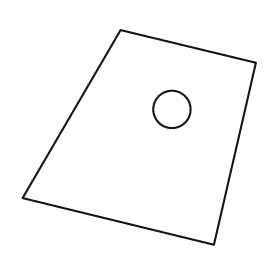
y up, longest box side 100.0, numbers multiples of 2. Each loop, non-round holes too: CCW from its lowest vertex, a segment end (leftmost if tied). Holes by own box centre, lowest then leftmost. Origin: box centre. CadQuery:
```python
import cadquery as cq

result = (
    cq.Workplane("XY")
    .moveTo(32.0, -46.0)
    .lineTo(50.0, 32.0)
    .lineTo(-8.0, 46.0)
    .lineTo(-50.0, -26.0)
    .close()
    .moveTo(14.0, 12.0)
    .circle(8.0)
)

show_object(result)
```